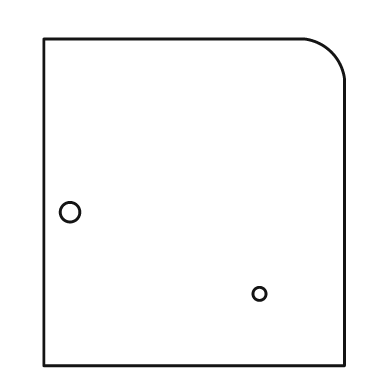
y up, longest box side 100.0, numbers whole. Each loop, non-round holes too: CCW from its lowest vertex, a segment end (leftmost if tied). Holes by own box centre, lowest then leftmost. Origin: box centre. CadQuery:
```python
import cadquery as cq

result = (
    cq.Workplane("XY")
    .moveTo(-46.0, -50.0)
    .lineTo(46.0, -50.0)
    .lineTo(46.0, 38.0)
    .threePointArc((42.0, 46.0), (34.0, 50.0))
    .lineTo(-46.0, 50.0)
    .close()
    .moveTo(20.0, -28.0)
    .circle(2.0)
    .moveTo(-38.0, -3.0)
    .circle(3.0)
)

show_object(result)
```